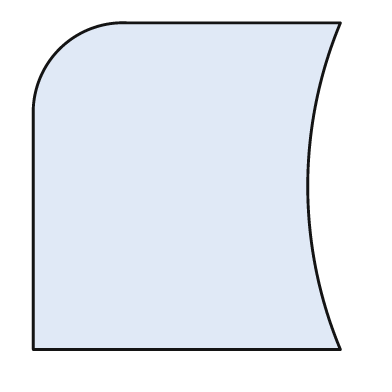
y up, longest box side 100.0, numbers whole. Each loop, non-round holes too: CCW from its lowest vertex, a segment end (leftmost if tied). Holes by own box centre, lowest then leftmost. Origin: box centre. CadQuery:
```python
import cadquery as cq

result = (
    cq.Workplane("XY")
    .moveTo(-47.0, -50.0)
    .lineTo(47.0, -50.0)
    .threePointArc((37.0, 0.0), (47.0, 50.0))
    .lineTo(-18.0, 50.0)
    .threePointArc((-39.0, 42.0), (-47.0, 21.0))
    .close()
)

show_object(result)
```